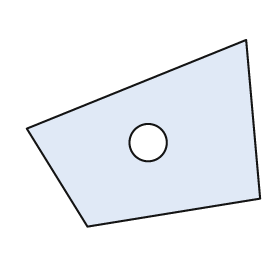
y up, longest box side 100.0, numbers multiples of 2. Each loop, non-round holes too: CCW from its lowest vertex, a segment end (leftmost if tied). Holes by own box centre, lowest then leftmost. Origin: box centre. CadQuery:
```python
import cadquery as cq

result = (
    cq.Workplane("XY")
    .moveTo(-24.0, -40.0)
    .lineTo(50.0, -28.0)
    .lineTo(44.0, 40.0)
    .lineTo(-50.0, 2.0)
    .close()
    .moveTo(2.0, -4.0)
    .circle(8.0)
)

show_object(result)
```